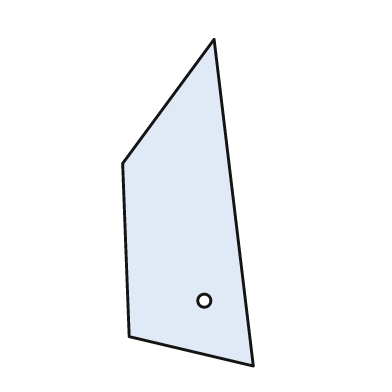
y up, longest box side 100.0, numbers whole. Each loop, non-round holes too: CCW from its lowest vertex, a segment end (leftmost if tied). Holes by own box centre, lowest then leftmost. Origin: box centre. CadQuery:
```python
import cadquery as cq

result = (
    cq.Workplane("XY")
    .moveTo(20.0, -50.0)
    .lineTo(8.0, 50.0)
    .lineTo(-20.0, 12.0)
    .lineTo(-18.0, -41.0)
    .close()
    .moveTo(5.0, -30.0)
    .circle(2.0)
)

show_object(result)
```